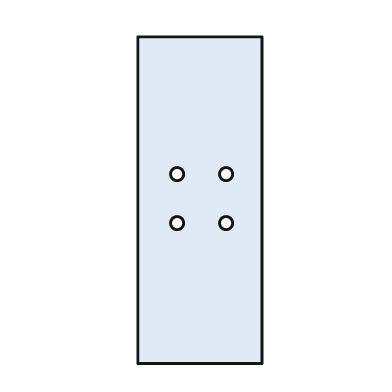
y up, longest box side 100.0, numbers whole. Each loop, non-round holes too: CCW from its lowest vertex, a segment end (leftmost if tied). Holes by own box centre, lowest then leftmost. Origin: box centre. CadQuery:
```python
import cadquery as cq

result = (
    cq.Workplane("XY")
    .moveTo(-19.0, -50.0)
    .lineTo(19.0, -50.0)
    .lineTo(19.0, 50.0)
    .lineTo(-19.0, 50.0)
    .close()
    .moveTo(-7.0, -7.0)
    .circle(2.0)
    .moveTo(8.0, -7.0)
    .circle(2.0)
    .moveTo(-7.0, 8.0)
    .circle(2.0)
    .moveTo(8.0, 8.0)
    .circle(2.0)
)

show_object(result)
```